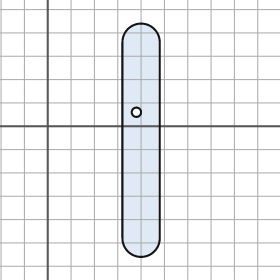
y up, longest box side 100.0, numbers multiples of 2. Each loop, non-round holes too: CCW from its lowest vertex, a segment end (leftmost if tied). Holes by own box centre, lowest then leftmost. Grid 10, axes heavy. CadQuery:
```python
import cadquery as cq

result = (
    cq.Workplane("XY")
    .moveTo(32.0, -48.0)
    .threePointArc((40.0, -56.0), (48.0, -48.0))
    .lineTo(48.0, 36.0)
    .threePointArc((40.0, 44.0), (32.0, 36.0))
    .close()
    .moveTo(38.0, 6.0)
    .circle(2.0)
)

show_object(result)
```